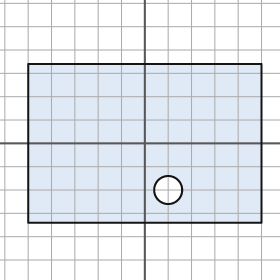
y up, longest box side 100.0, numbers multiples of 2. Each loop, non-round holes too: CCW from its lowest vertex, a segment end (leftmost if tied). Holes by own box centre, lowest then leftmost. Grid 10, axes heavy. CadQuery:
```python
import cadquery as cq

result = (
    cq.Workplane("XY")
    .moveTo(-50.0, -34.0)
    .lineTo(50.0, -34.0)
    .lineTo(50.0, 34.0)
    .lineTo(-50.0, 34.0)
    .close()
    .moveTo(10.0, -20.0)
    .circle(6.0)
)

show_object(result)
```